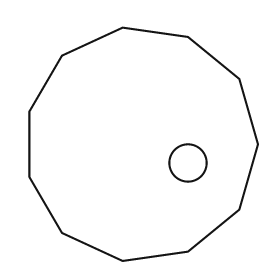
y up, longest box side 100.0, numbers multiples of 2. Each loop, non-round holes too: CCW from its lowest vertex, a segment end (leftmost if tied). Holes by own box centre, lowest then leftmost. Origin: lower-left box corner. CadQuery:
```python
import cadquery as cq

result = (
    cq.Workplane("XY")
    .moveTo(40.0, 0.0)
    .lineTo(68.0, 4.0)
    .lineTo(90.0, 22.0)
    .lineTo(98.0, 50.0)
    .lineTo(90.0, 78.0)
    .lineTo(68.0, 96.0)
    .lineTo(40.0, 100.0)
    .lineTo(14.0, 88.0)
    .lineTo(0.0, 64.0)
    .lineTo(0.0, 36.0)
    .lineTo(14.0, 12.0)
    .close()
    .moveTo(68.0, 42.0)
    .circle(8.0)
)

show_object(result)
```